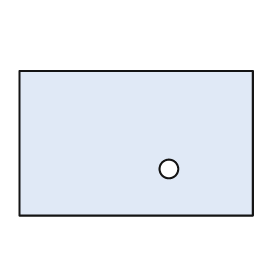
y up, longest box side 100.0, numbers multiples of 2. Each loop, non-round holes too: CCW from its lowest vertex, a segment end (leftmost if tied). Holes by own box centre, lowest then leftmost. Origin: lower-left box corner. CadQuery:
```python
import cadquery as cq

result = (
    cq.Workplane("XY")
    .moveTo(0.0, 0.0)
    .lineTo(100.0, 0.0)
    .lineTo(100.0, 62.0)
    .lineTo(0.0, 62.0)
    .close()
    .moveTo(64.0, 20.0)
    .circle(4.0)
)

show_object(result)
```